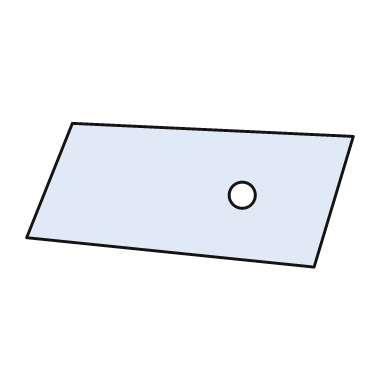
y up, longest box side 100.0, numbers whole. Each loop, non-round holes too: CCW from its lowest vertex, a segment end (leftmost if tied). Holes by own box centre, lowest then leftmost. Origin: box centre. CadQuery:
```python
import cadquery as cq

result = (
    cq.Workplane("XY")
    .moveTo(38.0, -22.0)
    .lineTo(50.0, 18.0)
    .lineTo(-36.0, 22.0)
    .lineTo(-50.0, -13.0)
    .close()
    .moveTo(16.0, 0.0)
    .circle(4.0)
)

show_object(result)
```